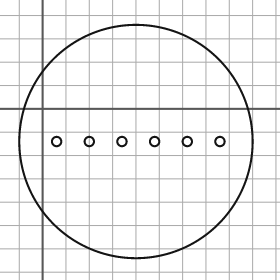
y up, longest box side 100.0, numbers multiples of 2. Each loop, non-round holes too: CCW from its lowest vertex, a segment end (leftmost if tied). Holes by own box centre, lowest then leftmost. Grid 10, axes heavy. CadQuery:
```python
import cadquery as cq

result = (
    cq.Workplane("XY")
    .moveTo(40.0, -14.0)
    .circle(50.0)
    .moveTo(6.0, -14.0)
    .circle(2.0)
    .moveTo(20.0, -14.0)
    .circle(2.0)
    .moveTo(34.0, -14.0)
    .circle(2.0)
    .moveTo(48.0, -14.0)
    .circle(2.0)
    .moveTo(62.0, -14.0)
    .circle(2.0)
    .moveTo(76.0, -14.0)
    .circle(2.0)
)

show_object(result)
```